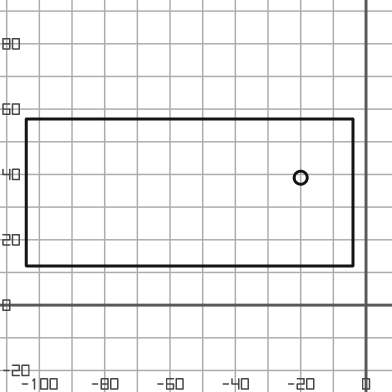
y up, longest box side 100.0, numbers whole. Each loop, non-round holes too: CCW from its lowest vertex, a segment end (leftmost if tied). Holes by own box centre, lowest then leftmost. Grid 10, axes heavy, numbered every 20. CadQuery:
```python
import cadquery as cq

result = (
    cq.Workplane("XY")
    .moveTo(-104.0, 12.0)
    .lineTo(-4.0, 12.0)
    .lineTo(-4.0, 57.0)
    .lineTo(-104.0, 57.0)
    .close()
    .moveTo(-20.0, 39.0)
    .circle(2.0)
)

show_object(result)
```